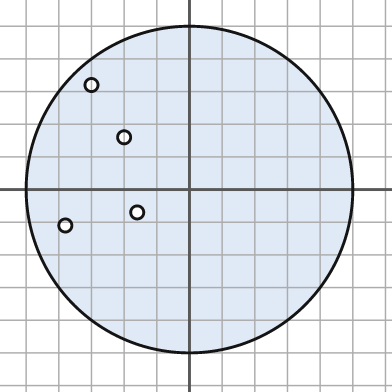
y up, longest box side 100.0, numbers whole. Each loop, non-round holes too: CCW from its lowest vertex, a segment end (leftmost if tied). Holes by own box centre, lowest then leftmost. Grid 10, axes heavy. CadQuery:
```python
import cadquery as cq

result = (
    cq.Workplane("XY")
    .moveTo(0.0, 0.0)
    .circle(50.0)
    .moveTo(-38.0, -11.0)
    .circle(2.0)
    .moveTo(-16.0, -7.0)
    .circle(2.0)
    .moveTo(-20.0, 16.0)
    .circle(2.0)
    .moveTo(-30.0, 32.0)
    .circle(2.0)
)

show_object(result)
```